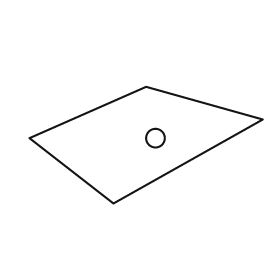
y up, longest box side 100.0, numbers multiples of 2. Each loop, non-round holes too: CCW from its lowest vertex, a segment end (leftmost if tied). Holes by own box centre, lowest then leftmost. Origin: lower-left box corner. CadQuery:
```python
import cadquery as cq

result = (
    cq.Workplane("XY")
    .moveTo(36.0, 0.0)
    .lineTo(100.0, 36.0)
    .lineTo(50.0, 50.0)
    .lineTo(0.0, 28.0)
    .close()
    .moveTo(54.0, 28.0)
    .circle(4.0)
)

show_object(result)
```